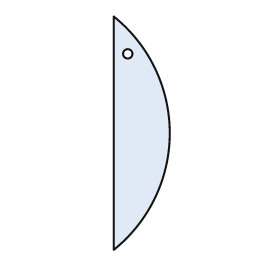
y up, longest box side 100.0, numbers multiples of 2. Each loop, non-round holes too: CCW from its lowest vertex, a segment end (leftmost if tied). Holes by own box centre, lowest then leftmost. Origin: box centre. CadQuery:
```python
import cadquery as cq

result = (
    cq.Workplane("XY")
    .moveTo(-12.0, -50.0)
    .threePointArc((12.0, 0.0), (-12.0, 50.0))
    .close()
    .moveTo(-6.0, 34.0)
    .circle(2.0)
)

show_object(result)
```